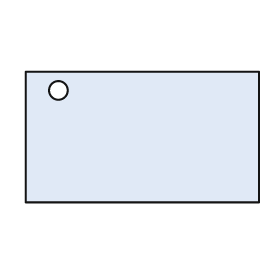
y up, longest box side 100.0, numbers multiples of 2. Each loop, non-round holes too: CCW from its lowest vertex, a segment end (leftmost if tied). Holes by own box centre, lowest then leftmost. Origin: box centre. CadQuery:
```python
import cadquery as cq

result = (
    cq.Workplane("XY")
    .moveTo(-50.0, -28.0)
    .lineTo(50.0, -28.0)
    .lineTo(50.0, 28.0)
    .lineTo(-50.0, 28.0)
    .close()
    .moveTo(-36.0, 20.0)
    .circle(4.0)
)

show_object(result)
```